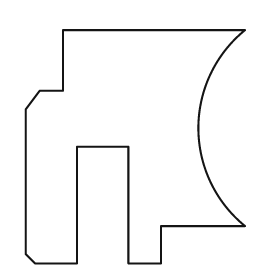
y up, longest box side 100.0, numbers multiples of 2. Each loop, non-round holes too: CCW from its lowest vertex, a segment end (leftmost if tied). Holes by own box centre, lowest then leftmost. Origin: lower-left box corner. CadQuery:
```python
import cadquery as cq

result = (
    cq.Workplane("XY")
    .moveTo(4.0, 0.0)
    .lineTo(22.0, 0.0)
    .lineTo(22.0, 50.0)
    .lineTo(44.0, 50.0)
    .lineTo(44.0, 0.0)
    .lineTo(58.0, 0.0)
    .lineTo(58.0, 16.0)
    .lineTo(94.0, 16.0)
    .threePointArc((74.0, 58.0), (94.0, 100.0))
    .lineTo(16.0, 100.0)
    .lineTo(16.0, 74.0)
    .lineTo(6.0, 74.0)
    .lineTo(0.0, 66.0)
    .lineTo(0.0, 4.0)
    .close()
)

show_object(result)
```